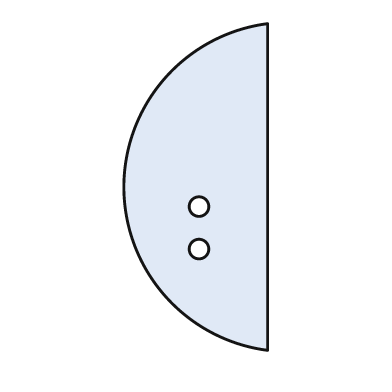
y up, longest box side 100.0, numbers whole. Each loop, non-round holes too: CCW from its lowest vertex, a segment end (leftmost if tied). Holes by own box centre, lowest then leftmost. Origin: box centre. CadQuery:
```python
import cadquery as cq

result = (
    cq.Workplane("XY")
    .moveTo(22.0, -50.0)
    .lineTo(22.0, 50.0)
    .threePointArc((-22.0, 0.0), (22.0, -50.0))
    .close()
    .moveTo(1.0, -19.0)
    .circle(3.0)
    .moveTo(1.0, -6.0)
    .circle(3.0)
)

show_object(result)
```